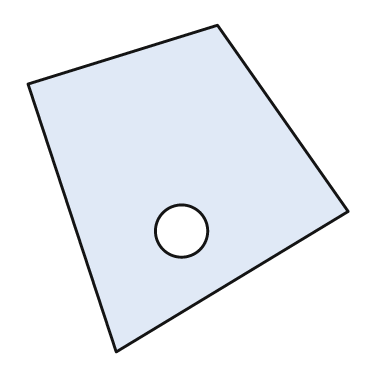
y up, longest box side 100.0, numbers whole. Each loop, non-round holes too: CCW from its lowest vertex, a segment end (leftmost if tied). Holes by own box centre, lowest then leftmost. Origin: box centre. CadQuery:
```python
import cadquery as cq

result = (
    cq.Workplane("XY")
    .moveTo(-22.0, -50.0)
    .lineTo(49.0, -7.0)
    .lineTo(9.0, 50.0)
    .lineTo(-49.0, 32.0)
    .close()
    .moveTo(-2.0, -13.0)
    .circle(8.0)
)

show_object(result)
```